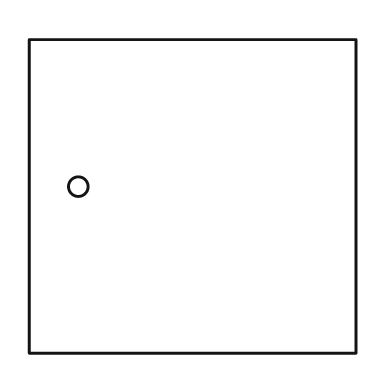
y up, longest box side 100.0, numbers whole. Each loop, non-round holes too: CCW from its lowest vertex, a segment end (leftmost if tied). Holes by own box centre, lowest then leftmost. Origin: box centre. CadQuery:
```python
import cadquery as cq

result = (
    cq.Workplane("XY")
    .moveTo(-50.0, -48.0)
    .lineTo(50.0, -48.0)
    .lineTo(50.0, 48.0)
    .lineTo(-50.0, 48.0)
    .close()
    .moveTo(-35.0, 3.0)
    .circle(3.0)
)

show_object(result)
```